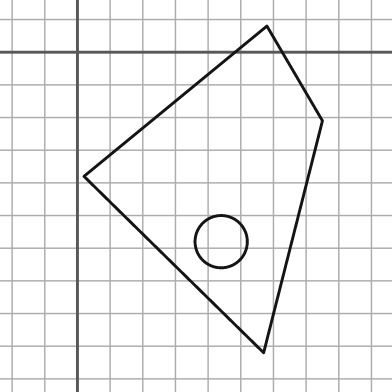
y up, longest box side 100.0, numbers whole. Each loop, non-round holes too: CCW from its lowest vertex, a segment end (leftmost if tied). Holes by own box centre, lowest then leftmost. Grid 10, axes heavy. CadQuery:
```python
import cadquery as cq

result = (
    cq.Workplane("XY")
    .moveTo(57.0, -92.0)
    .lineTo(75.0, -21.0)
    .lineTo(58.0, 8.0)
    .lineTo(2.0, -38.0)
    .close()
    .moveTo(44.0, -58.0)
    .circle(8.0)
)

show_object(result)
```